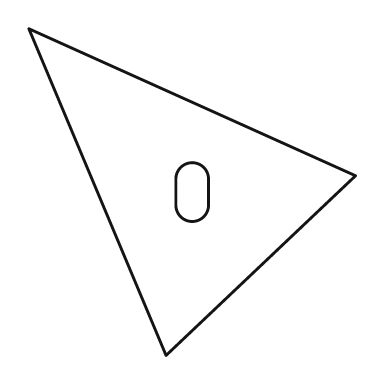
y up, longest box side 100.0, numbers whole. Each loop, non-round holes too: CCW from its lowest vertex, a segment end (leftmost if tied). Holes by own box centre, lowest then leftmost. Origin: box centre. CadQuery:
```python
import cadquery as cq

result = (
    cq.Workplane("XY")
    .moveTo(-8.0, -50.0)
    .lineTo(50.0, 5.0)
    .lineTo(-50.0, 50.0)
    .close()
    .moveTo(-5.0, -4.0)
    .threePointArc((0.0, -9.0), (5.0, -4.0))
    .lineTo(5.0, 4.0)
    .threePointArc((0.0, 9.0), (-5.0, 4.0))
    .close()
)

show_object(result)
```